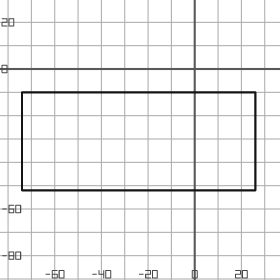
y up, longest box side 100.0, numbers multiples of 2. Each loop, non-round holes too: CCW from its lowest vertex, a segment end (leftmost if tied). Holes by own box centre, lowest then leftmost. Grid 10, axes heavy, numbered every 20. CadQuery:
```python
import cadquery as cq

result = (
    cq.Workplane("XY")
    .moveTo(-74.0, -52.0)
    .lineTo(26.0, -52.0)
    .lineTo(26.0, -10.0)
    .lineTo(-74.0, -10.0)
    .close()
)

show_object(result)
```